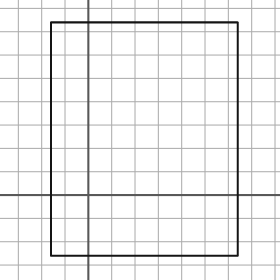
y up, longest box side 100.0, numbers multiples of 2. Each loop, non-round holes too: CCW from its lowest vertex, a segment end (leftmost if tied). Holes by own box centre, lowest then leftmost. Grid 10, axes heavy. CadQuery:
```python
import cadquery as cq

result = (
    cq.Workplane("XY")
    .moveTo(-16.0, -26.0)
    .lineTo(64.0, -26.0)
    .lineTo(64.0, 74.0)
    .lineTo(-16.0, 74.0)
    .close()
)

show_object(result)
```